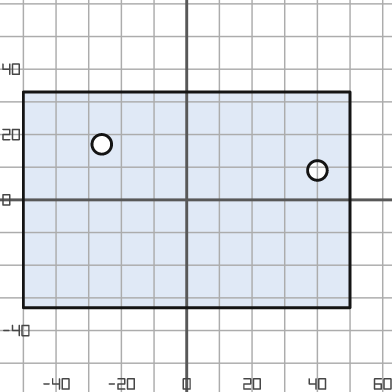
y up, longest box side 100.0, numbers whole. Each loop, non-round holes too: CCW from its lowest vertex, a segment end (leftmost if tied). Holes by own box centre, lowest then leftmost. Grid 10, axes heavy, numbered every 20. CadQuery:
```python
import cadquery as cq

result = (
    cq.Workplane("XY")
    .moveTo(-50.0, -33.0)
    .lineTo(50.0, -33.0)
    .lineTo(50.0, 33.0)
    .lineTo(-50.0, 33.0)
    .close()
    .moveTo(40.0, 9.0)
    .circle(3.0)
    .moveTo(-26.0, 17.0)
    .circle(3.0)
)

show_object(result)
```